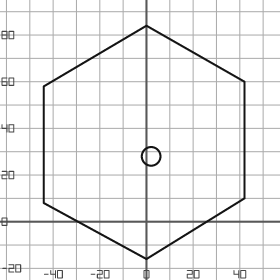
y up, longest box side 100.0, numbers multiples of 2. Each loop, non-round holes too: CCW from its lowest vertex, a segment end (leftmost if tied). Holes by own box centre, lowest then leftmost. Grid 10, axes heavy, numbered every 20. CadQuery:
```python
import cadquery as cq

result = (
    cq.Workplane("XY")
    .moveTo(0.0, -16.0)
    .lineTo(42.0, 10.0)
    .lineTo(42.0, 60.0)
    .lineTo(0.0, 84.0)
    .lineTo(-44.0, 58.0)
    .lineTo(-44.0, 8.0)
    .close()
    .moveTo(2.0, 28.0)
    .circle(4.0)
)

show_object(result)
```